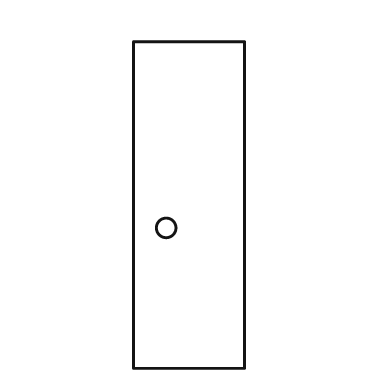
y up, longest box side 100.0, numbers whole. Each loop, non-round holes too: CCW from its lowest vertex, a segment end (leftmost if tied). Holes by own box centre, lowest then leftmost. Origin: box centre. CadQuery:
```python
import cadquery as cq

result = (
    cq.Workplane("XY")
    .moveTo(-17.0, -50.0)
    .lineTo(17.0, -50.0)
    .lineTo(17.0, 50.0)
    .lineTo(-17.0, 50.0)
    .close()
    .moveTo(-7.0, -7.0)
    .circle(3.0)
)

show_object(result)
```